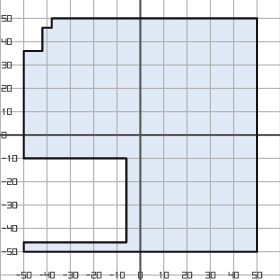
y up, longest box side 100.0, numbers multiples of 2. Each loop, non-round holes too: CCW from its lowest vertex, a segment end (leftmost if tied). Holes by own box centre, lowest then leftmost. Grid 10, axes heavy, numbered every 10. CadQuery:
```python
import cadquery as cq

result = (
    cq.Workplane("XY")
    .moveTo(-50.0, -50.0)
    .lineTo(50.0, -50.0)
    .lineTo(50.0, 50.0)
    .lineTo(-38.0, 50.0)
    .lineTo(-38.0, 46.0)
    .lineTo(-42.0, 46.0)
    .lineTo(-42.0, 36.0)
    .lineTo(-50.0, 36.0)
    .lineTo(-50.0, -10.0)
    .lineTo(-6.0, -10.0)
    .lineTo(-6.0, -46.0)
    .lineTo(-50.0, -46.0)
    .close()
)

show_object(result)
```